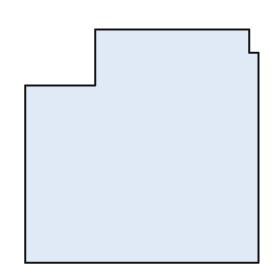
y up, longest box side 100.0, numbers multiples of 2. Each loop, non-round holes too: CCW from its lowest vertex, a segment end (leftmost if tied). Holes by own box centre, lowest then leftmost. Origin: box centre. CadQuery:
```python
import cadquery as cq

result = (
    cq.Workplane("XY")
    .moveTo(-50.0, -50.0)
    .lineTo(50.0, -50.0)
    .lineTo(50.0, 40.0)
    .lineTo(46.0, 40.0)
    .lineTo(46.0, 50.0)
    .lineTo(-20.0, 50.0)
    .lineTo(-20.0, 26.0)
    .lineTo(-50.0, 26.0)
    .close()
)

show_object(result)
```